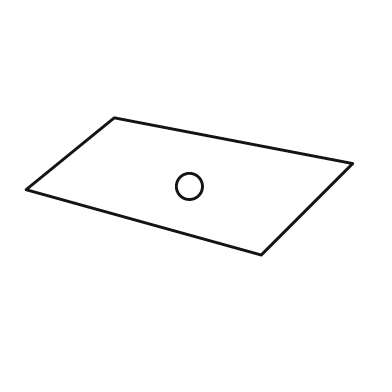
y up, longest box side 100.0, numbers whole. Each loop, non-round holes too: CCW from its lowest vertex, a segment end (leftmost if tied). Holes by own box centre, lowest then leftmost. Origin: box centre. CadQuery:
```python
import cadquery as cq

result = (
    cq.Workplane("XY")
    .moveTo(22.0, -21.0)
    .lineTo(50.0, 7.0)
    .lineTo(-23.0, 21.0)
    .lineTo(-50.0, -1.0)
    .close()
    .moveTo(0.0, 0.0)
    .circle(4.0)
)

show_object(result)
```